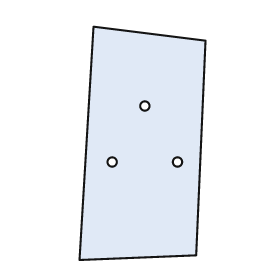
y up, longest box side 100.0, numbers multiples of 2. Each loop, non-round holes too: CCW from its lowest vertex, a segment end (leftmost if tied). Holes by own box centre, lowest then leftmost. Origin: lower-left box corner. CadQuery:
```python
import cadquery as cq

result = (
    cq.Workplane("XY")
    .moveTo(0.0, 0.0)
    .lineTo(50.0, 2.0)
    .lineTo(54.0, 94.0)
    .lineTo(6.0, 100.0)
    .close()
    .moveTo(14.0, 42.0)
    .circle(2.0)
    .moveTo(42.0, 42.0)
    .circle(2.0)
    .moveTo(28.0, 66.0)
    .circle(2.0)
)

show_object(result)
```